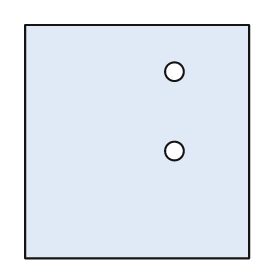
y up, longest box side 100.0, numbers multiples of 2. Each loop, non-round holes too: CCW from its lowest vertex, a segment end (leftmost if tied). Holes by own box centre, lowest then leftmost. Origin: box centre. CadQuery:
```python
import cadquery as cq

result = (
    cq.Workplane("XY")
    .moveTo(-48.0, -50.0)
    .lineTo(48.0, -50.0)
    .lineTo(48.0, 50.0)
    .lineTo(-48.0, 50.0)
    .close()
    .moveTo(16.0, -4.0)
    .circle(4.0)
    .moveTo(16.0, 30.0)
    .circle(4.0)
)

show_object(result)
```